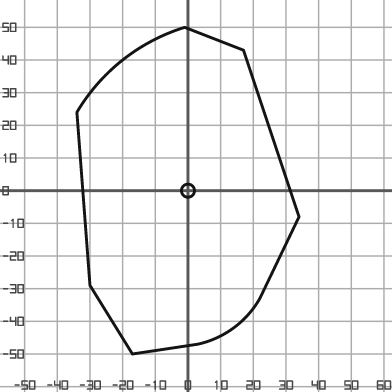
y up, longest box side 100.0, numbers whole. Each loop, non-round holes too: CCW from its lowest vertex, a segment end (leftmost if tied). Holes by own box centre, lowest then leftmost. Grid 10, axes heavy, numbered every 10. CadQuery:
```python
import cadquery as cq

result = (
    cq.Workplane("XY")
    .moveTo(-17.0, -50.0)
    .lineTo(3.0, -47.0)
    .threePointArc((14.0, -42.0), (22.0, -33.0))
    .lineTo(34.0, -8.0)
    .lineTo(17.0, 43.0)
    .lineTo(-1.0, 50.0)
    .threePointArc((-20.0, 40.0), (-34.0, 24.0))
    .lineTo(-30.0, -29.0)
    .close()
    .moveTo(0.0, 0.0)
    .circle(2.0)
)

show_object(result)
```